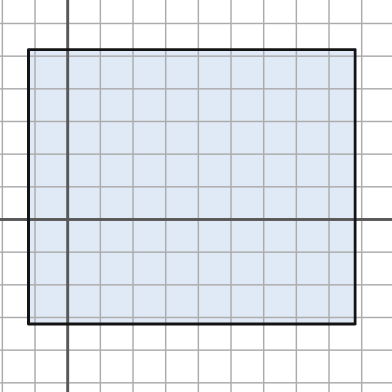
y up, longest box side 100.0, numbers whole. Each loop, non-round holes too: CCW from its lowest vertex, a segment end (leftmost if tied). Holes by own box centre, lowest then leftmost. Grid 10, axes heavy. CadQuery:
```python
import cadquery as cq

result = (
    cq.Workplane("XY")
    .moveTo(-12.0, -32.0)
    .lineTo(88.0, -32.0)
    .lineTo(88.0, 52.0)
    .lineTo(-12.0, 52.0)
    .close()
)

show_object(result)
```